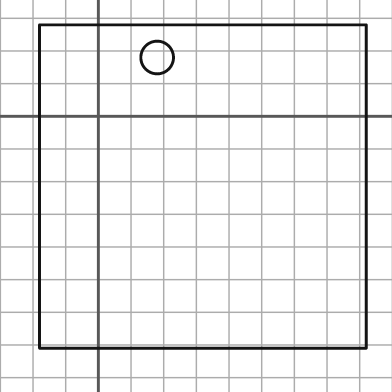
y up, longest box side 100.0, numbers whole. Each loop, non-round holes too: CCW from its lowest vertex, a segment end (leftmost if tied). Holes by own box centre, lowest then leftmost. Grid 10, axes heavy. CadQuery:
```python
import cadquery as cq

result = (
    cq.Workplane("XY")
    .moveTo(-18.0, -71.0)
    .lineTo(82.0, -71.0)
    .lineTo(82.0, 28.0)
    .lineTo(-18.0, 28.0)
    .close()
    .moveTo(18.0, 18.0)
    .circle(5.0)
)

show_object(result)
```